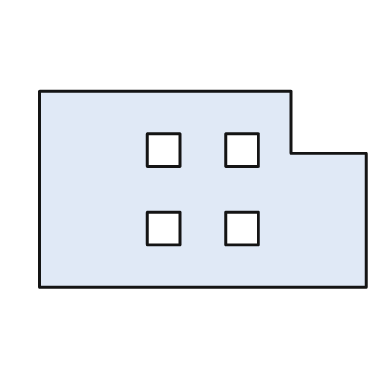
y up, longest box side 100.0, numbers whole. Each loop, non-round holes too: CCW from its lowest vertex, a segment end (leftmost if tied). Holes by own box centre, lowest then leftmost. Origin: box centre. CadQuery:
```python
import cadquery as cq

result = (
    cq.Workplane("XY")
    .moveTo(-50.0, -30.0)
    .lineTo(50.0, -30.0)
    .lineTo(50.0, 11.0)
    .lineTo(27.0, 11.0)
    .lineTo(27.0, 30.0)
    .lineTo(-50.0, 30.0)
    .close()
    .moveTo(-17.0, -17.0)
    .lineTo(-7.0, -17.0)
    .lineTo(-7.0, -7.0)
    .lineTo(-17.0, -7.0)
    .close()
    .moveTo(7.0, -17.0)
    .lineTo(17.0, -17.0)
    .lineTo(17.0, -7.0)
    .lineTo(7.0, -7.0)
    .close()
    .moveTo(-17.0, 7.0)
    .lineTo(-7.0, 7.0)
    .lineTo(-7.0, 17.0)
    .lineTo(-17.0, 17.0)
    .close()
    .moveTo(7.0, 7.0)
    .lineTo(17.0, 7.0)
    .lineTo(17.0, 17.0)
    .lineTo(7.0, 17.0)
    .close()
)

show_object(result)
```